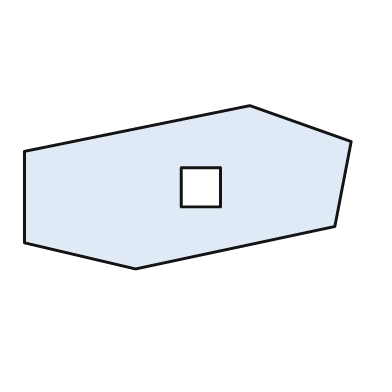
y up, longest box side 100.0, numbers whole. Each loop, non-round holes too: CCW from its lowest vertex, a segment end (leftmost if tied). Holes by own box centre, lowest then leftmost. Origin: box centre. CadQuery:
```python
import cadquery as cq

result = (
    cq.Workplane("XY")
    .moveTo(-16.0, -25.0)
    .lineTo(45.0, -12.0)
    .lineTo(50.0, 14.0)
    .lineTo(19.0, 25.0)
    .lineTo(-50.0, 11.0)
    .lineTo(-50.0, -17.0)
    .close()
    .moveTo(-2.0, -6.0)
    .lineTo(10.0, -6.0)
    .lineTo(10.0, 6.0)
    .lineTo(-2.0, 6.0)
    .close()
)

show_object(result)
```